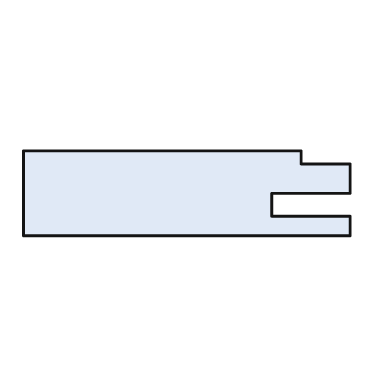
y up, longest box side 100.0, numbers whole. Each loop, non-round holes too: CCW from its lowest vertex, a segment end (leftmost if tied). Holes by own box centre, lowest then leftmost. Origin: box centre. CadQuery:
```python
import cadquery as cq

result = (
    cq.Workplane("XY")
    .moveTo(-50.0, -13.0)
    .lineTo(50.0, -13.0)
    .lineTo(50.0, -7.0)
    .lineTo(26.0, -7.0)
    .lineTo(26.0, 0.0)
    .lineTo(50.0, 0.0)
    .lineTo(50.0, 9.0)
    .lineTo(35.0, 9.0)
    .lineTo(35.0, 13.0)
    .lineTo(-50.0, 13.0)
    .close()
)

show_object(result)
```